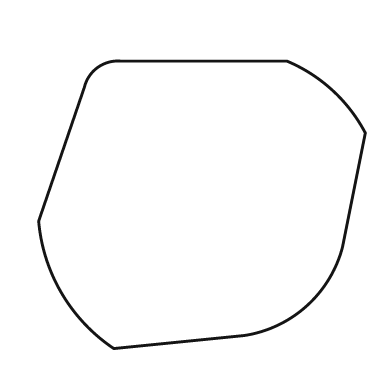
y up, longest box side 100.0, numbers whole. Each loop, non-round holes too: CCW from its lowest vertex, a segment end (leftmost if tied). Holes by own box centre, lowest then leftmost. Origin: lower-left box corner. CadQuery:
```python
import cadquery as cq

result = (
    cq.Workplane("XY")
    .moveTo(23.0, 0.0)
    .lineTo(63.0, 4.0)
    .threePointArc((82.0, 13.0), (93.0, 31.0))
    .lineTo(100.0, 66.0)
    .threePointArc((90.0, 79.0), (76.0, 88.0))
    .lineTo(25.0, 88.0)
    .threePointArc((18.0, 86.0), (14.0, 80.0))
    .lineTo(0.0, 39.0)
    .threePointArc((7.0, 17.0), (23.0, 0.0))
    .close()
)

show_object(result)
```